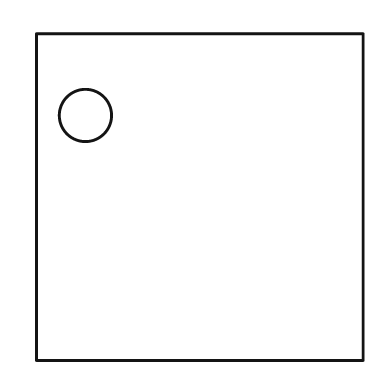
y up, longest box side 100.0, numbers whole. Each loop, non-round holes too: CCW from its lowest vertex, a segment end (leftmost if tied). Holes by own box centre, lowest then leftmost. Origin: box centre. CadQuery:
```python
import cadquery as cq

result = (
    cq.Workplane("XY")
    .moveTo(-50.0, -50.0)
    .lineTo(50.0, -50.0)
    .lineTo(50.0, 50.0)
    .lineTo(-50.0, 50.0)
    .close()
    .moveTo(-35.0, 25.0)
    .circle(8.0)
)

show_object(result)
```